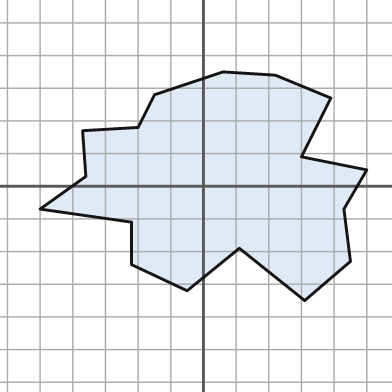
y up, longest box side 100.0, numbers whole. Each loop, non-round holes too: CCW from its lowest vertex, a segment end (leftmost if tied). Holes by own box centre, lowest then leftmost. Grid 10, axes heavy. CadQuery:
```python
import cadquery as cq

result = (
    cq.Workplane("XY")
    .moveTo(31.0, -35.0)
    .lineTo(45.0, -23.0)
    .lineTo(43.0, -7.0)
    .lineTo(50.0, 5.0)
    .lineTo(30.0, 9.0)
    .lineTo(39.0, 27.0)
    .lineTo(22.0, 34.0)
    .lineTo(6.0, 35.0)
    .lineTo(-15.0, 28.0)
    .lineTo(-20.0, 18.0)
    .lineTo(-37.0, 17.0)
    .lineTo(-36.0, 3.0)
    .lineTo(-50.0, -7.0)
    .lineTo(-22.0, -11.0)
    .lineTo(-22.0, -24.0)
    .lineTo(-5.0, -32.0)
    .lineTo(11.0, -19.0)
    .close()
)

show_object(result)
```